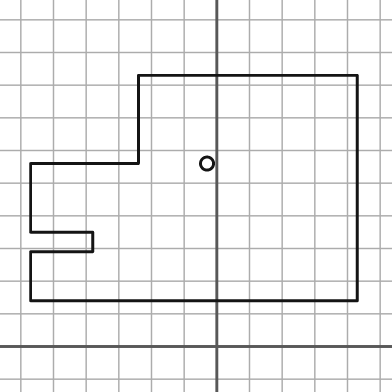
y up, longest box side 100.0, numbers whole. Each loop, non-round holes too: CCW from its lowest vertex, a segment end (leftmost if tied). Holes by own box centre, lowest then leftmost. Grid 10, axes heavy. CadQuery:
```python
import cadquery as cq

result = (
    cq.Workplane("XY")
    .moveTo(-57.0, 14.0)
    .lineTo(43.0, 14.0)
    .lineTo(43.0, 83.0)
    .lineTo(-24.0, 83.0)
    .lineTo(-24.0, 56.0)
    .lineTo(-57.0, 56.0)
    .lineTo(-57.0, 35.0)
    .lineTo(-38.0, 35.0)
    .lineTo(-38.0, 29.0)
    .lineTo(-57.0, 29.0)
    .close()
    .moveTo(-3.0, 56.0)
    .circle(2.0)
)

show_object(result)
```